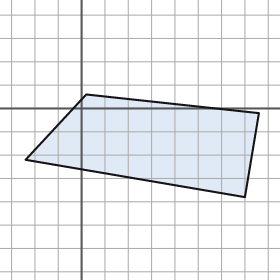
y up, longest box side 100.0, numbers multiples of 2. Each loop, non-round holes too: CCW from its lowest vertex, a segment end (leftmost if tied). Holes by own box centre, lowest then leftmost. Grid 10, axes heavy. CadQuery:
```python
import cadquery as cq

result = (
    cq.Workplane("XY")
    .moveTo(70.0, -38.0)
    .lineTo(76.0, -2.0)
    .lineTo(2.0, 6.0)
    .lineTo(-24.0, -22.0)
    .close()
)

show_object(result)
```